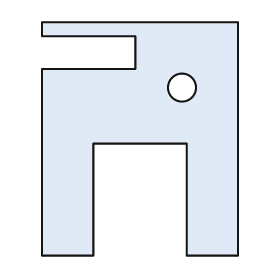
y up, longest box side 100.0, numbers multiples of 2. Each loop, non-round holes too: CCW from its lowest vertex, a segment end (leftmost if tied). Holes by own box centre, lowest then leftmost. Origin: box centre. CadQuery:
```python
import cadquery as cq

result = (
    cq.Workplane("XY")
    .moveTo(-42.0, -50.0)
    .lineTo(-20.0, -50.0)
    .lineTo(-20.0, -2.0)
    .lineTo(20.0, -2.0)
    .lineTo(20.0, -50.0)
    .lineTo(42.0, -50.0)
    .lineTo(42.0, 50.0)
    .lineTo(-42.0, 50.0)
    .lineTo(-42.0, 44.0)
    .lineTo(-2.0, 44.0)
    .lineTo(-2.0, 30.0)
    .lineTo(-42.0, 30.0)
    .close()
    .moveTo(18.0, 22.0)
    .circle(6.0)
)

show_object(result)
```